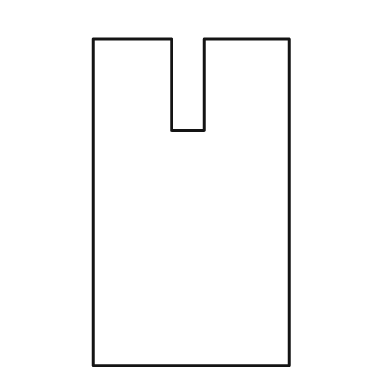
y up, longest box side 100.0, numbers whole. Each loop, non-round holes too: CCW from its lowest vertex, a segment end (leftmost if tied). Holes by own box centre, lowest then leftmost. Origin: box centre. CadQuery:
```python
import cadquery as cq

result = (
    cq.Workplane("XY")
    .moveTo(-30.0, -50.0)
    .lineTo(30.0, -50.0)
    .lineTo(30.0, 50.0)
    .lineTo(4.0, 50.0)
    .lineTo(4.0, 22.0)
    .lineTo(-6.0, 22.0)
    .lineTo(-6.0, 50.0)
    .lineTo(-30.0, 50.0)
    .close()
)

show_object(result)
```